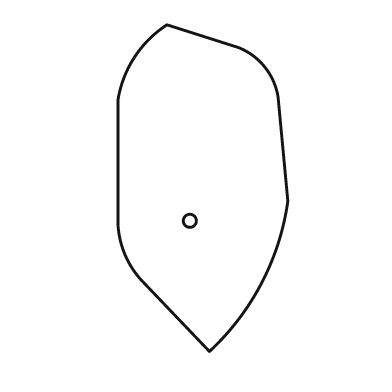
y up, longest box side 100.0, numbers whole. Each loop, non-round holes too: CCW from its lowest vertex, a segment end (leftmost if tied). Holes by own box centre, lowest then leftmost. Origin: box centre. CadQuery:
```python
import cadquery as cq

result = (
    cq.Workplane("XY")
    .moveTo(2.0, -50.0)
    .threePointArc((18.0, -29.0), (26.0, -4.0))
    .lineTo(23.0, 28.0)
    .threePointArc((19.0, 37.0), (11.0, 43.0))
    .lineTo(-11.0, 50.0)
    .threePointArc((-21.0, 40.0), (-26.0, 27.0))
    .lineTo(-26.0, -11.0)
    .threePointArc((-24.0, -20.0), (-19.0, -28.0))
    .close()
    .moveTo(-4.0, -10.0)
    .circle(2.0)
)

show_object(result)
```